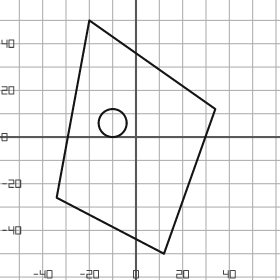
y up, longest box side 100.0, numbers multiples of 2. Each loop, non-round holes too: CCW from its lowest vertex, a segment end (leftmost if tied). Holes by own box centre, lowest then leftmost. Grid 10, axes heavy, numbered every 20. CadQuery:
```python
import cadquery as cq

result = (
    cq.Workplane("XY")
    .moveTo(12.0, -50.0)
    .lineTo(34.0, 12.0)
    .lineTo(-20.0, 50.0)
    .lineTo(-34.0, -26.0)
    .close()
    .moveTo(-10.0, 6.0)
    .circle(6.0)
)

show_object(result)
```